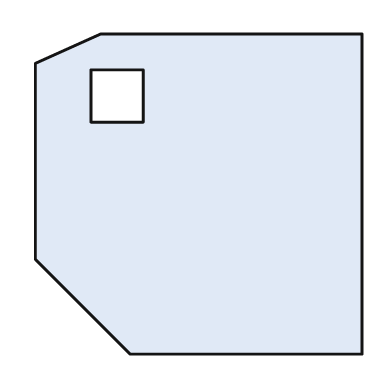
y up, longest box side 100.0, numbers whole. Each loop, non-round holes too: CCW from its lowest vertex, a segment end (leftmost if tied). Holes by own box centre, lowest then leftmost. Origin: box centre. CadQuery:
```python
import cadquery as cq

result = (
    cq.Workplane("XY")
    .moveTo(-21.0, -49.0)
    .lineTo(50.0, -49.0)
    .lineTo(50.0, 49.0)
    .lineTo(-30.0, 49.0)
    .lineTo(-50.0, 40.0)
    .lineTo(-50.0, -20.0)
    .close()
    .moveTo(-33.0, 22.0)
    .lineTo(-17.0, 22.0)
    .lineTo(-17.0, 38.0)
    .lineTo(-33.0, 38.0)
    .close()
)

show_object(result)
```